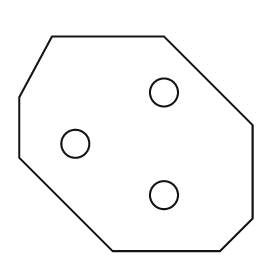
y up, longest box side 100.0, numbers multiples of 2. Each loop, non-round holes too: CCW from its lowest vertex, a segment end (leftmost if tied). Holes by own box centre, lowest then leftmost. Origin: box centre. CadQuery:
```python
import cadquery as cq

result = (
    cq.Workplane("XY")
    .moveTo(-10.0, -46.0)
    .lineTo(36.0, -46.0)
    .lineTo(50.0, -32.0)
    .lineTo(50.0, 8.0)
    .lineTo(12.0, 46.0)
    .lineTo(-36.0, 46.0)
    .lineTo(-50.0, 20.0)
    .lineTo(-50.0, -6.0)
    .close()
    .moveTo(12.0, -22.0)
    .circle(6.0)
    .moveTo(-26.0, 0.0)
    .circle(6.0)
    .moveTo(12.0, 22.0)
    .circle(6.0)
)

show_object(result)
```